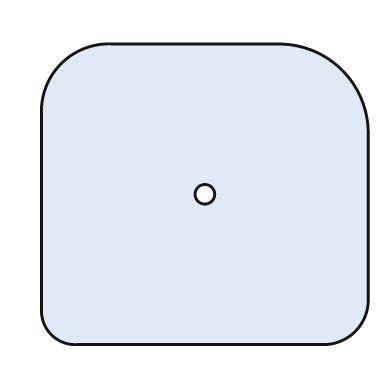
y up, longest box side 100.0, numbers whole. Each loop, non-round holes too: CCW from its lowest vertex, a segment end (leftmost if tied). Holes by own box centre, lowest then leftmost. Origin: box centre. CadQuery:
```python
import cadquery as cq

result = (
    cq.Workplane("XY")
    .moveTo(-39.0, -46.0)
    .lineTo(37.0, -46.0)
    .threePointArc((46.0, -42.0), (50.0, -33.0))
    .lineTo(50.0, 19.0)
    .threePointArc((42.0, 38.0), (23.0, 46.0))
    .lineTo(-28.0, 46.0)
    .threePointArc((-44.0, 40.0), (-50.0, 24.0))
    .lineTo(-50.0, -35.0)
    .threePointArc((-47.0, -43.0), (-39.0, -46.0))
    .close()
    .moveTo(0.0, 0.0)
    .circle(3.0)
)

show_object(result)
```